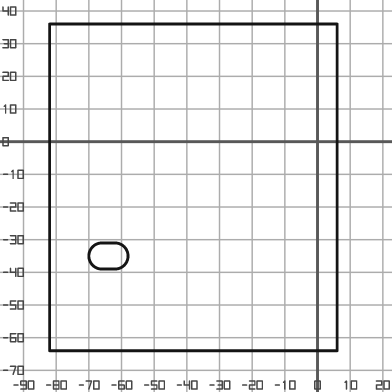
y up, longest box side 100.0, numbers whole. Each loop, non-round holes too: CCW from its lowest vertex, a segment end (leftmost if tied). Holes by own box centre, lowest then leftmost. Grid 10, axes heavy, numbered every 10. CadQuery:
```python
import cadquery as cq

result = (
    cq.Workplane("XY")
    .moveTo(-82.0, -64.0)
    .lineTo(6.0, -64.0)
    .lineTo(6.0, 36.0)
    .lineTo(-82.0, 36.0)
    .close()
    .moveTo(-66.0, -39.0)
    .lineTo(-62.0, -39.0)
    .threePointArc((-58.0, -35.0), (-62.0, -31.0))
    .lineTo(-66.0, -31.0)
    .threePointArc((-70.0, -35.0), (-66.0, -39.0))
    .close()
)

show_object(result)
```